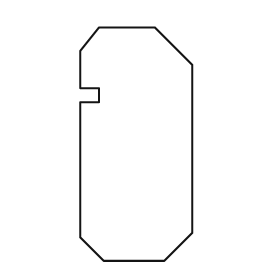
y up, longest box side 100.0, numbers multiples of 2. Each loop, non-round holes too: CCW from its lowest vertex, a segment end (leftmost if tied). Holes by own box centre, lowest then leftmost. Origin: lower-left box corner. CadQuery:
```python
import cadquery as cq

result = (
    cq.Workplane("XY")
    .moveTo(10.0, 0.0)
    .lineTo(36.0, 0.0)
    .lineTo(48.0, 12.0)
    .lineTo(48.0, 84.0)
    .lineTo(32.0, 100.0)
    .lineTo(8.0, 100.0)
    .lineTo(0.0, 90.0)
    .lineTo(0.0, 74.0)
    .lineTo(8.0, 74.0)
    .lineTo(8.0, 68.0)
    .lineTo(0.0, 68.0)
    .lineTo(0.0, 10.0)
    .close()
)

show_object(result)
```